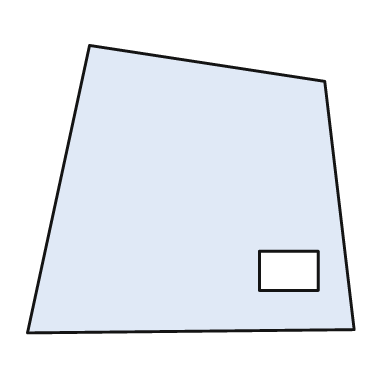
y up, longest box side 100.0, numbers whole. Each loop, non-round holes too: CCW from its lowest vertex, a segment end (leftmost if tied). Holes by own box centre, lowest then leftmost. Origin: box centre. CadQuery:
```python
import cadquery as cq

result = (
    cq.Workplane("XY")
    .moveTo(-50.0, -44.0)
    .lineTo(50.0, -43.0)
    .lineTo(41.0, 33.0)
    .lineTo(-31.0, 44.0)
    .close()
    .moveTo(21.0, -31.0)
    .lineTo(39.0, -31.0)
    .lineTo(39.0, -19.0)
    .lineTo(21.0, -19.0)
    .close()
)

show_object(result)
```